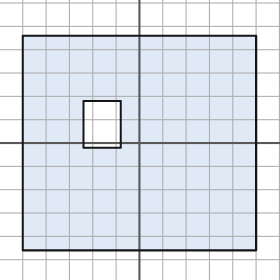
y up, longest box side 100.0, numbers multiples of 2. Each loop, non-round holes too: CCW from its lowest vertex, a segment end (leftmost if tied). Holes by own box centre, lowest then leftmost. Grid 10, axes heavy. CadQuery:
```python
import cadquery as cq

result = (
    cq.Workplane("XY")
    .moveTo(-50.0, -46.0)
    .lineTo(50.0, -46.0)
    .lineTo(50.0, 46.0)
    .lineTo(-50.0, 46.0)
    .close()
    .moveTo(-24.0, -2.0)
    .lineTo(-8.0, -2.0)
    .lineTo(-8.0, 18.0)
    .lineTo(-24.0, 18.0)
    .close()
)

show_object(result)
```